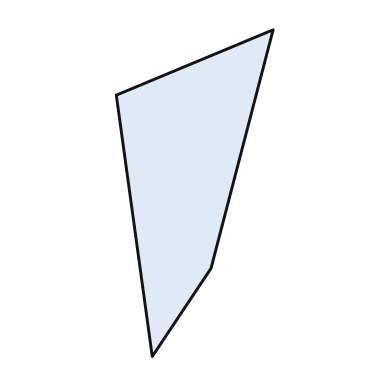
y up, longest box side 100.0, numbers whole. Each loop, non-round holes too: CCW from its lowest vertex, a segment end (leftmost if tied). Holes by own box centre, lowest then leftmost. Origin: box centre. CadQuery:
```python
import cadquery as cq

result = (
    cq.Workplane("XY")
    .moveTo(-13.0, -50.0)
    .lineTo(5.0, -23.0)
    .lineTo(24.0, 50.0)
    .lineTo(-24.0, 30.0)
    .close()
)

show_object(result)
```